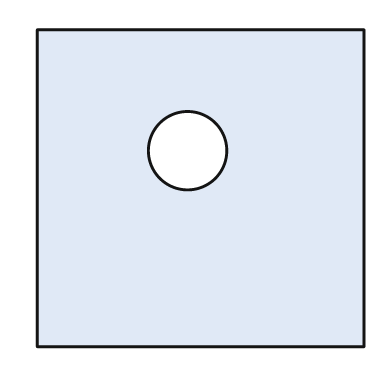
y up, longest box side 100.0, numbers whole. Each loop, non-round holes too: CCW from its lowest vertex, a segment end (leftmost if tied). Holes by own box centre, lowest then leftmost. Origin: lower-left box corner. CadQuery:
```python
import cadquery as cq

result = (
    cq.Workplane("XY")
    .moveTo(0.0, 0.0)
    .lineTo(100.0, 0.0)
    .lineTo(100.0, 97.0)
    .lineTo(0.0, 97.0)
    .close()
    .moveTo(46.0, 60.0)
    .circle(12.0)
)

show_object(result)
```